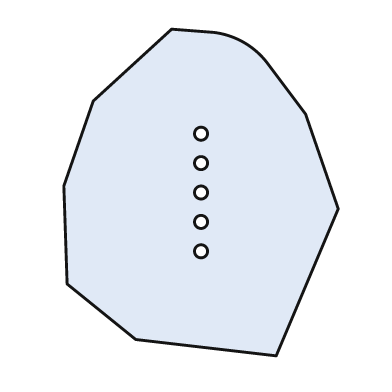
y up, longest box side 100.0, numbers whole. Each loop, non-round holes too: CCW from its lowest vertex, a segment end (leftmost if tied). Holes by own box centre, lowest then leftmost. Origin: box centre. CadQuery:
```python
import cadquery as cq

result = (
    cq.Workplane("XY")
    .moveTo(23.0, -50.0)
    .lineTo(42.0, -5.0)
    .lineTo(32.0, 24.0)
    .lineTo(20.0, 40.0)
    .threePointArc((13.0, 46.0), (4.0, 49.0))
    .lineTo(-9.0, 50.0)
    .lineTo(-33.0, 28.0)
    .lineTo(-42.0, 2.0)
    .lineTo(-41.0, -28.0)
    .lineTo(-20.0, -45.0)
    .close()
    .moveTo(0.0, -18.0)
    .circle(2.0)
    .moveTo(0.0, -9.0)
    .circle(2.0)
    .moveTo(0.0, 0.0)
    .circle(2.0)
    .moveTo(0.0, 9.0)
    .circle(2.0)
    .moveTo(0.0, 18.0)
    .circle(2.0)
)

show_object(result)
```